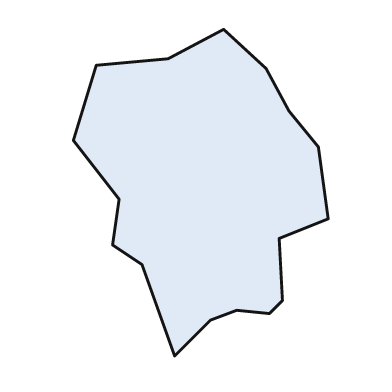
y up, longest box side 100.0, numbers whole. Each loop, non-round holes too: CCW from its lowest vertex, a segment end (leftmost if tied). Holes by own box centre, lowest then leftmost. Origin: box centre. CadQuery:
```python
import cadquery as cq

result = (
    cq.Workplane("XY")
    .moveTo(-8.0, -50.0)
    .lineTo(3.0, -39.0)
    .lineTo(11.0, -36.0)
    .lineTo(21.0, -37.0)
    .lineTo(25.0, -33.0)
    .lineTo(24.0, -14.0)
    .lineTo(39.0, -8.0)
    .lineTo(36.0, 14.0)
    .lineTo(27.0, 25.0)
    .lineTo(20.0, 38.0)
    .lineTo(7.0, 50.0)
    .lineTo(-10.0, 41.0)
    .lineTo(-32.0, 39.0)
    .lineTo(-39.0, 16.0)
    .lineTo(-25.0, -2.0)
    .lineTo(-27.0, -16.0)
    .lineTo(-18.0, -22.0)
    .close()
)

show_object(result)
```